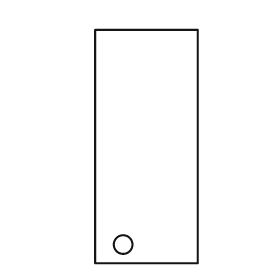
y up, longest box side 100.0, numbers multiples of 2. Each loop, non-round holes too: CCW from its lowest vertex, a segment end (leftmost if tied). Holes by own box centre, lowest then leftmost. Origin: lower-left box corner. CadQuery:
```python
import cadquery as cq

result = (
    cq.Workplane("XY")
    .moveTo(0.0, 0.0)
    .lineTo(44.0, 0.0)
    .lineTo(44.0, 100.0)
    .lineTo(0.0, 100.0)
    .close()
    .moveTo(12.0, 8.0)
    .circle(4.0)
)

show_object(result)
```